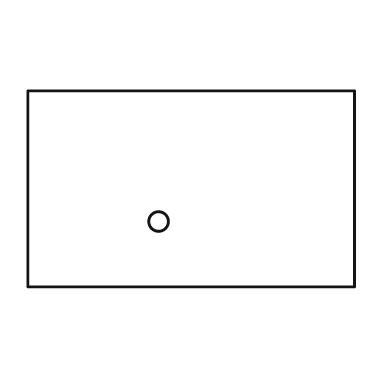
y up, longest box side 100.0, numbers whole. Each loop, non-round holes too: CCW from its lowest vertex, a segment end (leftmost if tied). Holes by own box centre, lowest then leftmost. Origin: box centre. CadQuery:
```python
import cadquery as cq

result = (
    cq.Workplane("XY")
    .moveTo(-50.0, -30.0)
    .lineTo(50.0, -30.0)
    .lineTo(50.0, 30.0)
    .lineTo(-50.0, 30.0)
    .close()
    .moveTo(-10.0, -10.0)
    .circle(3.0)
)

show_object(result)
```